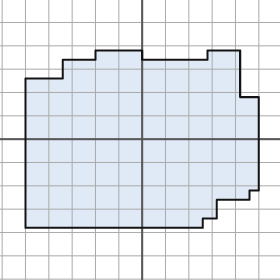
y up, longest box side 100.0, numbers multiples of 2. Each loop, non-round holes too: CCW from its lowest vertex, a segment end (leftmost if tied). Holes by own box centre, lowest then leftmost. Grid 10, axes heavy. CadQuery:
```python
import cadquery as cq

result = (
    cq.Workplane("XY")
    .moveTo(-50.0, -38.0)
    .lineTo(26.0, -38.0)
    .lineTo(26.0, -34.0)
    .lineTo(32.0, -34.0)
    .lineTo(32.0, -26.0)
    .lineTo(46.0, -26.0)
    .lineTo(46.0, -22.0)
    .lineTo(50.0, -22.0)
    .lineTo(50.0, 18.0)
    .lineTo(42.0, 18.0)
    .lineTo(42.0, 38.0)
    .lineTo(28.0, 38.0)
    .lineTo(28.0, 34.0)
    .lineTo(0.0, 34.0)
    .lineTo(0.0, 38.0)
    .lineTo(-20.0, 38.0)
    .lineTo(-20.0, 34.0)
    .lineTo(-34.0, 34.0)
    .lineTo(-34.0, 26.0)
    .lineTo(-50.0, 26.0)
    .close()
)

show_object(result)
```